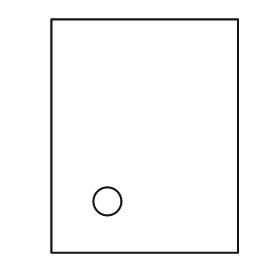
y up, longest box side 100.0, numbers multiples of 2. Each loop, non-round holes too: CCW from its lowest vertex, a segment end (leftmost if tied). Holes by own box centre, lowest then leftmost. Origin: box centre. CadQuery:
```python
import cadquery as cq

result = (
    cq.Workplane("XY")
    .moveTo(-40.0, -50.0)
    .lineTo(40.0, -50.0)
    .lineTo(40.0, 50.0)
    .lineTo(-40.0, 50.0)
    .close()
    .moveTo(-16.0, -28.0)
    .circle(6.0)
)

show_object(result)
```